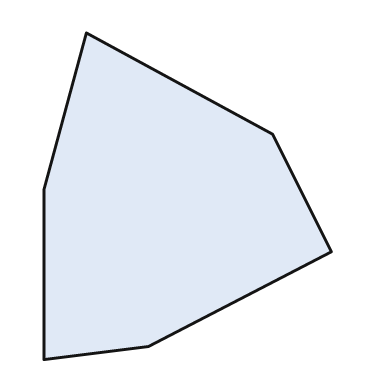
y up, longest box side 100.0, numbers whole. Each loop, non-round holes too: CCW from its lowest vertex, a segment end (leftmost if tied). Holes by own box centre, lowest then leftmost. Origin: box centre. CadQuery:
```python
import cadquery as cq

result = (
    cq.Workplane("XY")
    .moveTo(-44.0, -50.0)
    .lineTo(-12.0, -46.0)
    .lineTo(44.0, -17.0)
    .lineTo(26.0, 19.0)
    .lineTo(-31.0, 50.0)
    .lineTo(-44.0, 2.0)
    .close()
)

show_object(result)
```